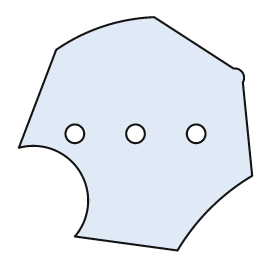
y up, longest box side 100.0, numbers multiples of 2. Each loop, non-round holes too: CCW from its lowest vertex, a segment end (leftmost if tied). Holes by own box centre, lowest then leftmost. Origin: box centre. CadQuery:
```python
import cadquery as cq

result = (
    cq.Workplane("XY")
    .moveTo(18.0, -50.0)
    .threePointArc((32.0, -32.0), (50.0, -18.0))
    .lineTo(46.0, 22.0)
    .threePointArc((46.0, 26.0), (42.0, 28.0))
    .lineTo(8.0, 50.0)
    .threePointArc((-14.0, 46.0), (-34.0, 36.0))
    .lineTo(-50.0, -6.0)
    .threePointArc((-24.0, -16.0), (-26.0, -44.0))
    .close()
    .moveTo(-26.0, 0.0)
    .circle(4.0)
    .moveTo(0.0, 0.0)
    .circle(4.0)
    .moveTo(26.0, 0.0)
    .circle(4.0)
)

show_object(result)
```